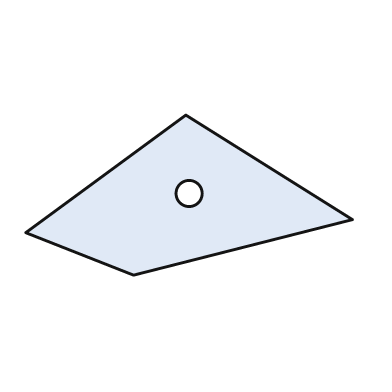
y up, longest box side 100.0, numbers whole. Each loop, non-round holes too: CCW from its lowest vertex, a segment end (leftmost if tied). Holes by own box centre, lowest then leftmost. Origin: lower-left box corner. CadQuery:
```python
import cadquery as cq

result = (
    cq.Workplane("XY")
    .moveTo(33.0, 0.0)
    .lineTo(100.0, 17.0)
    .lineTo(49.0, 49.0)
    .lineTo(0.0, 13.0)
    .close()
    .moveTo(50.0, 25.0)
    .circle(4.0)
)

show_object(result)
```